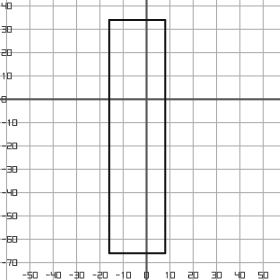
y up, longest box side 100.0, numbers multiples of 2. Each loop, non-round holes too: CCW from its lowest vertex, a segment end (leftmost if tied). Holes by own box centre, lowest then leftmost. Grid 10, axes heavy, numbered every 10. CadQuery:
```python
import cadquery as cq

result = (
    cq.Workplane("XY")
    .moveTo(-16.0, -66.0)
    .lineTo(8.0, -66.0)
    .lineTo(8.0, 34.0)
    .lineTo(-16.0, 34.0)
    .close()
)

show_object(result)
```